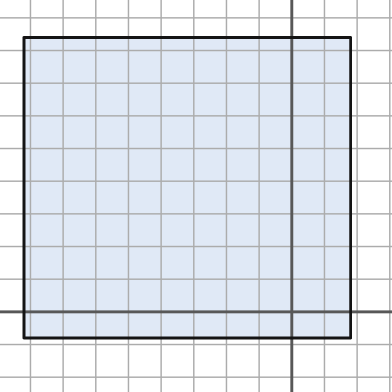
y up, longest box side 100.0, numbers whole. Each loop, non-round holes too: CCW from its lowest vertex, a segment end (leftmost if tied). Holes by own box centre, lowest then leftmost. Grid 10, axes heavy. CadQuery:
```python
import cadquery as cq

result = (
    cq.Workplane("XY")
    .moveTo(-82.0, -8.0)
    .lineTo(18.0, -8.0)
    .lineTo(18.0, 84.0)
    .lineTo(-82.0, 84.0)
    .close()
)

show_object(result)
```